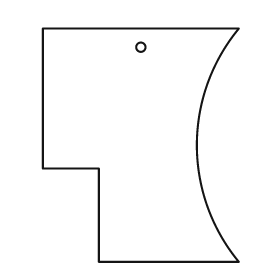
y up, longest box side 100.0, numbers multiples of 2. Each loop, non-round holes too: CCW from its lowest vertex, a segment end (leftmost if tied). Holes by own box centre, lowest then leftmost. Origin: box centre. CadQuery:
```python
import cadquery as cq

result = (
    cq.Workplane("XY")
    .moveTo(-18.0, -50.0)
    .lineTo(42.0, -50.0)
    .threePointArc((24.0, 0.0), (42.0, 50.0))
    .lineTo(-42.0, 50.0)
    .lineTo(-42.0, -10.0)
    .lineTo(-18.0, -10.0)
    .close()
    .moveTo(0.0, 42.0)
    .circle(2.0)
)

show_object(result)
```